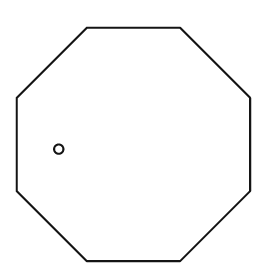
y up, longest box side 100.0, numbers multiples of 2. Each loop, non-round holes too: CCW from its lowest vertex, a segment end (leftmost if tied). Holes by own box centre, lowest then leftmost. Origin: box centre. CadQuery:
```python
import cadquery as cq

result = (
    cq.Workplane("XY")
    .moveTo(-20.0, -50.0)
    .lineTo(20.0, -50.0)
    .lineTo(50.0, -20.0)
    .lineTo(50.0, 20.0)
    .lineTo(20.0, 50.0)
    .lineTo(-20.0, 50.0)
    .lineTo(-50.0, 20.0)
    .lineTo(-50.0, -20.0)
    .close()
    .moveTo(-32.0, -2.0)
    .circle(2.0)
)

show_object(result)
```